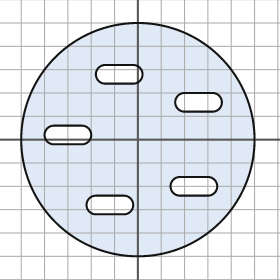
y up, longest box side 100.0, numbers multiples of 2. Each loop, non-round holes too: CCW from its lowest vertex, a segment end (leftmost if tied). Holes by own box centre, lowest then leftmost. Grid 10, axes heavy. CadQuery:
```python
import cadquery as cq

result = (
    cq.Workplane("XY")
    .moveTo(0.0, 0.0)
    .circle(50.0)
    .moveTo(-18.0, -32.0)
    .lineTo(-6.0, -32.0)
    .threePointArc((-2.0, -28.0), (-6.0, -24.0))
    .lineTo(-18.0, -24.0)
    .threePointArc((-22.0, -28.0), (-18.0, -32.0))
    .close()
    .moveTo(18.0, -24.0)
    .lineTo(30.0, -24.0)
    .threePointArc((34.0, -20.0), (30.0, -16.0))
    .lineTo(18.0, -16.0)
    .threePointArc((14.0, -20.0), (18.0, -24.0))
    .close()
    .moveTo(-36.0, -2.0)
    .lineTo(-24.0, -2.0)
    .threePointArc((-20.0, 2.0), (-24.0, 6.0))
    .lineTo(-36.0, 6.0)
    .threePointArc((-40.0, 2.0), (-36.0, -2.0))
    .close()
    .moveTo(20.0, 12.0)
    .lineTo(32.0, 12.0)
    .threePointArc((36.0, 16.0), (32.0, 20.0))
    .lineTo(20.0, 20.0)
    .threePointArc((16.0, 16.0), (20.0, 12.0))
    .close()
    .moveTo(-14.0, 24.0)
    .lineTo(-2.0, 24.0)
    .threePointArc((2.0, 28.0), (-2.0, 32.0))
    .lineTo(-14.0, 32.0)
    .threePointArc((-18.0, 28.0), (-14.0, 24.0))
    .close()
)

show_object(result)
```